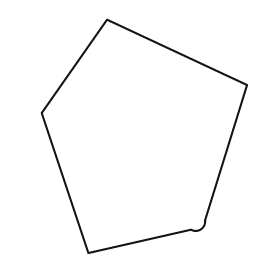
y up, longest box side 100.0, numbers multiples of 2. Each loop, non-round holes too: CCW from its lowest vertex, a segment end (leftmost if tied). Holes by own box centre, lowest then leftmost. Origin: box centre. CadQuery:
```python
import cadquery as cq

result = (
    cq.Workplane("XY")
    .moveTo(-24.0, -50.0)
    .lineTo(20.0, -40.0)
    .threePointArc((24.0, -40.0), (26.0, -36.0))
    .lineTo(44.0, 22.0)
    .lineTo(-16.0, 50.0)
    .lineTo(-44.0, 10.0)
    .close()
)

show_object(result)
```